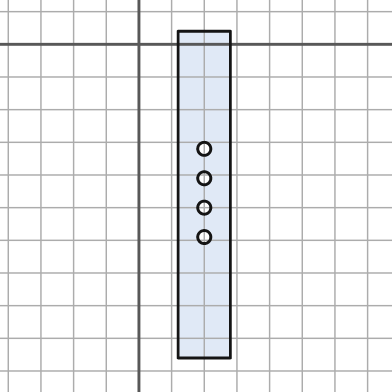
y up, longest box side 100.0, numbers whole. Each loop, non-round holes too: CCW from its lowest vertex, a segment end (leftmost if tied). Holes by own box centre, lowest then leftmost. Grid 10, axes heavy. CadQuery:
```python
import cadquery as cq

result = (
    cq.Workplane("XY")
    .moveTo(12.0, -96.0)
    .lineTo(28.0, -96.0)
    .lineTo(28.0, 4.0)
    .lineTo(12.0, 4.0)
    .close()
    .moveTo(20.0, -59.0)
    .circle(2.0)
    .moveTo(20.0, -50.0)
    .circle(2.0)
    .moveTo(20.0, -41.0)
    .circle(2.0)
    .moveTo(20.0, -32.0)
    .circle(2.0)
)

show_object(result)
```